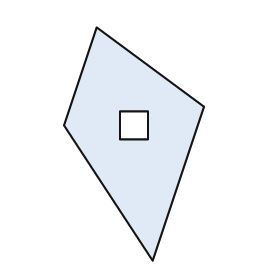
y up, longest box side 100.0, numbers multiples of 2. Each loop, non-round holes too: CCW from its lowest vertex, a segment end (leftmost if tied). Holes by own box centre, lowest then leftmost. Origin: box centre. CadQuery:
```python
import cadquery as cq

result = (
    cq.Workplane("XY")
    .moveTo(8.0, -50.0)
    .lineTo(30.0, 16.0)
    .lineTo(-16.0, 50.0)
    .lineTo(-30.0, 8.0)
    .close()
    .moveTo(-6.0, 2.0)
    .lineTo(6.0, 2.0)
    .lineTo(6.0, 14.0)
    .lineTo(-6.0, 14.0)
    .close()
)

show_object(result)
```